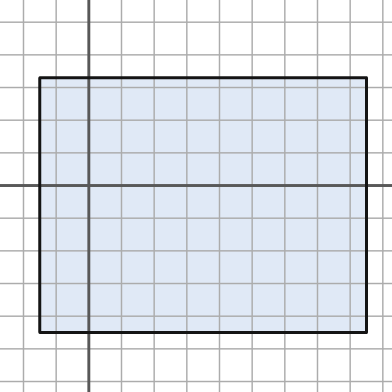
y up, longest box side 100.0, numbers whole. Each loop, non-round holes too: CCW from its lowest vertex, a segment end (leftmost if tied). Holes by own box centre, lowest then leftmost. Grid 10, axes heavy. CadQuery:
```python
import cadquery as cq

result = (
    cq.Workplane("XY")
    .moveTo(-15.0, -45.0)
    .lineTo(85.0, -45.0)
    .lineTo(85.0, 33.0)
    .lineTo(-15.0, 33.0)
    .close()
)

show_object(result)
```